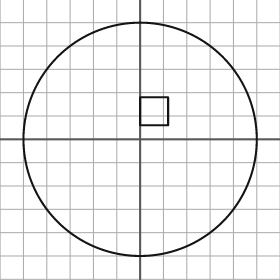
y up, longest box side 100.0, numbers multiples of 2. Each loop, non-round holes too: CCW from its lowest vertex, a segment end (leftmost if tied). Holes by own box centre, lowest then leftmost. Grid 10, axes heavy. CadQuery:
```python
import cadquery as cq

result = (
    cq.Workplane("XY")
    .moveTo(0.0, 0.0)
    .circle(50.0)
    .moveTo(0.0, 6.0)
    .lineTo(12.0, 6.0)
    .lineTo(12.0, 18.0)
    .lineTo(0.0, 18.0)
    .close()
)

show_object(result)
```